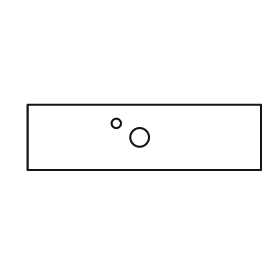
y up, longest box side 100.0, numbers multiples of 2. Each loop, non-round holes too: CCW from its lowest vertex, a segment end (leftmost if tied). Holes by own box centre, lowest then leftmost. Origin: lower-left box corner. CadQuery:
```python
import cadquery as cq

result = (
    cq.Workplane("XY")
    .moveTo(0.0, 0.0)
    .lineTo(100.0, 0.0)
    .lineTo(100.0, 28.0)
    .lineTo(0.0, 28.0)
    .close()
    .moveTo(48.0, 14.0)
    .circle(4.0)
    .moveTo(38.0, 20.0)
    .circle(2.0)
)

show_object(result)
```